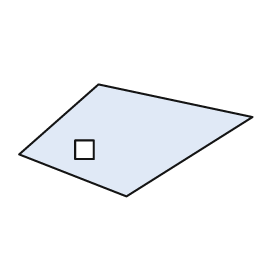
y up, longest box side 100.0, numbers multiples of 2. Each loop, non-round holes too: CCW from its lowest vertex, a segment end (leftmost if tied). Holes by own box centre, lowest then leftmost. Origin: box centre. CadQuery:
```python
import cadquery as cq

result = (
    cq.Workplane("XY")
    .moveTo(-4.0, -24.0)
    .lineTo(50.0, 10.0)
    .lineTo(-16.0, 24.0)
    .lineTo(-50.0, -6.0)
    .close()
    .moveTo(-26.0, -8.0)
    .lineTo(-18.0, -8.0)
    .lineTo(-18.0, 0.0)
    .lineTo(-26.0, 0.0)
    .close()
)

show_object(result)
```